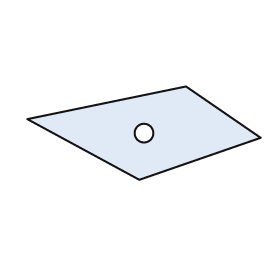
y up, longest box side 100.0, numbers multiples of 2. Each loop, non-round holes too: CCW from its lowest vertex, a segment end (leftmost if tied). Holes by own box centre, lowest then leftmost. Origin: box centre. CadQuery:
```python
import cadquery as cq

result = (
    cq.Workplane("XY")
    .moveTo(-2.0, -20.0)
    .lineTo(50.0, -2.0)
    .lineTo(18.0, 20.0)
    .lineTo(-50.0, 6.0)
    .close()
    .moveTo(0.0, 0.0)
    .circle(4.0)
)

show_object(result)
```